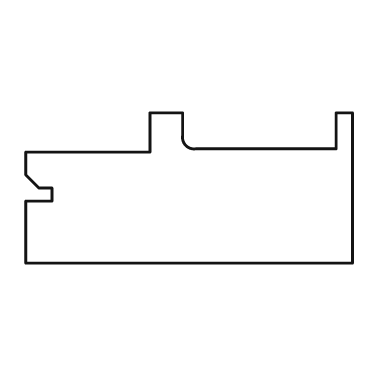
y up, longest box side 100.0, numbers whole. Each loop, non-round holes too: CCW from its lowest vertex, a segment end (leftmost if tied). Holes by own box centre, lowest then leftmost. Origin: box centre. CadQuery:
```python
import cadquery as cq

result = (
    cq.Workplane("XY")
    .moveTo(-50.0, -23.0)
    .lineTo(50.0, -23.0)
    .lineTo(50.0, 23.0)
    .lineTo(45.0, 23.0)
    .lineTo(45.0, 12.0)
    .lineTo(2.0, 12.0)
    .threePointArc((-1.0, 13.0), (-2.0, 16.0))
    .lineTo(-2.0, 23.0)
    .lineTo(-12.0, 23.0)
    .lineTo(-12.0, 11.0)
    .lineTo(-50.0, 11.0)
    .lineTo(-50.0, 4.0)
    .lineTo(-46.0, 0.0)
    .lineTo(-42.0, 0.0)
    .lineTo(-42.0, -4.0)
    .lineTo(-50.0, -4.0)
    .close()
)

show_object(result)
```